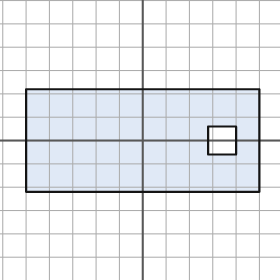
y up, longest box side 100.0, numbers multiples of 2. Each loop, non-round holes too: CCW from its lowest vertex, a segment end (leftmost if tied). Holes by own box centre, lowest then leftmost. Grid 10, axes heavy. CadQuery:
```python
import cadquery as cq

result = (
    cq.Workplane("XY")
    .moveTo(-50.0, -22.0)
    .lineTo(50.0, -22.0)
    .lineTo(50.0, 22.0)
    .lineTo(-50.0, 22.0)
    .close()
    .moveTo(28.0, -6.0)
    .lineTo(40.0, -6.0)
    .lineTo(40.0, 6.0)
    .lineTo(28.0, 6.0)
    .close()
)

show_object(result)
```